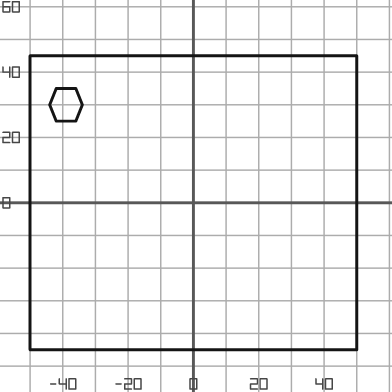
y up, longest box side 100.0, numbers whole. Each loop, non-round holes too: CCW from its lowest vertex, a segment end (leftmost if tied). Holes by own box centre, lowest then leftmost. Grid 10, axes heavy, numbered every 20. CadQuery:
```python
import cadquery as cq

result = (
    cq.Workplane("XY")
    .moveTo(-50.0, -45.0)
    .lineTo(50.0, -45.0)
    .lineTo(50.0, 45.0)
    .lineTo(-50.0, 45.0)
    .close()
    .moveTo(-42.0, 25.0)
    .lineTo(-36.0, 25.0)
    .lineTo(-34.0, 30.0)
    .lineTo(-36.0, 35.0)
    .lineTo(-42.0, 35.0)
    .lineTo(-44.0, 30.0)
    .close()
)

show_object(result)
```